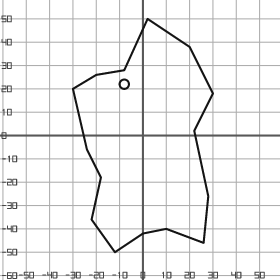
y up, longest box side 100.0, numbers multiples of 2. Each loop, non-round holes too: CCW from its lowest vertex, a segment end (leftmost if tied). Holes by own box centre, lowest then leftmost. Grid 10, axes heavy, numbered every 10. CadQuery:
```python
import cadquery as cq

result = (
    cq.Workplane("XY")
    .moveTo(-12.0, -50.0)
    .lineTo(0.0, -42.0)
    .lineTo(10.0, -40.0)
    .lineTo(26.0, -46.0)
    .lineTo(28.0, -26.0)
    .lineTo(22.0, 2.0)
    .lineTo(30.0, 18.0)
    .lineTo(20.0, 38.0)
    .lineTo(2.0, 50.0)
    .lineTo(-8.0, 28.0)
    .lineTo(-20.0, 26.0)
    .lineTo(-30.0, 20.0)
    .lineTo(-24.0, -6.0)
    .lineTo(-18.0, -18.0)
    .lineTo(-22.0, -36.0)
    .close()
    .moveTo(-8.0, 22.0)
    .circle(2.0)
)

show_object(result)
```